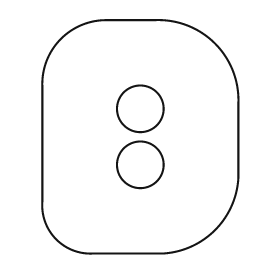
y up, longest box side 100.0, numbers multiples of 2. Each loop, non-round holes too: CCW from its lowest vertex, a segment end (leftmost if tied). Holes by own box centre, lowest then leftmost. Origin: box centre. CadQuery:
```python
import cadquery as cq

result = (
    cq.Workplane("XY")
    .moveTo(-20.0, -50.0)
    .lineTo(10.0, -50.0)
    .threePointArc((32.0, -40.0), (42.0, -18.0))
    .lineTo(42.0, 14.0)
    .threePointArc((32.0, 40.0), (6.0, 50.0))
    .lineTo(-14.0, 50.0)
    .threePointArc((-34.0, 42.0), (-42.0, 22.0))
    .lineTo(-42.0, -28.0)
    .threePointArc((-36.0, -44.0), (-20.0, -50.0))
    .close()
    .moveTo(0.0, -12.0)
    .circle(10.0)
    .moveTo(0.0, 12.0)
    .circle(10.0)
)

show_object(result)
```